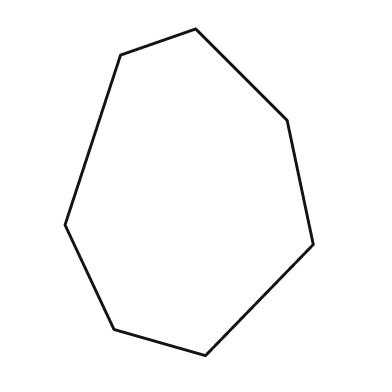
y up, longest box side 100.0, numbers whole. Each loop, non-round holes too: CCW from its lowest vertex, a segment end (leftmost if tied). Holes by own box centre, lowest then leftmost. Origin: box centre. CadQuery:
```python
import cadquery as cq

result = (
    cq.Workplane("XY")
    .moveTo(5.0, -50.0)
    .lineTo(38.0, -16.0)
    .lineTo(30.0, 22.0)
    .lineTo(2.0, 50.0)
    .lineTo(-21.0, 42.0)
    .lineTo(-38.0, -10.0)
    .lineTo(-23.0, -42.0)
    .close()
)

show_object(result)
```